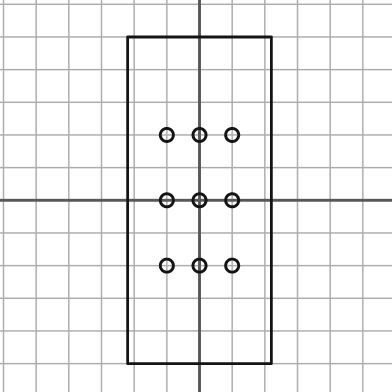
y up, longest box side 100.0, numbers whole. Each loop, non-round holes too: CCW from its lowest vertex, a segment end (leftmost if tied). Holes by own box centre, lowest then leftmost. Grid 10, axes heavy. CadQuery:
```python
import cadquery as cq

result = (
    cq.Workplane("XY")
    .moveTo(-22.0, -50.0)
    .lineTo(22.0, -50.0)
    .lineTo(22.0, 50.0)
    .lineTo(-22.0, 50.0)
    .close()
    .moveTo(-10.0, -20.0)
    .circle(2.0)
    .moveTo(0.0, -20.0)
    .circle(2.0)
    .moveTo(10.0, -20.0)
    .circle(2.0)
    .moveTo(-10.0, 0.0)
    .circle(2.0)
    .moveTo(0.0, 0.0)
    .circle(2.0)
    .moveTo(10.0, 0.0)
    .circle(2.0)
    .moveTo(-10.0, 20.0)
    .circle(2.0)
    .moveTo(0.0, 20.0)
    .circle(2.0)
    .moveTo(10.0, 20.0)
    .circle(2.0)
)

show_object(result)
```